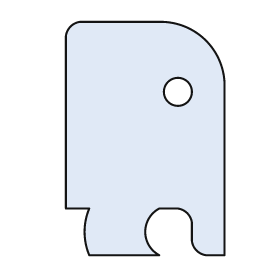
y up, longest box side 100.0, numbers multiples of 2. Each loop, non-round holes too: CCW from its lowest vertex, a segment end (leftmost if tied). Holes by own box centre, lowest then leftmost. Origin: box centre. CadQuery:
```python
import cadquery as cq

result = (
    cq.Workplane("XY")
    .moveTo(-24.0, -50.0)
    .lineTo(6.0, -50.0)
    .threePointArc((0.0, -40.0), (6.0, -30.0))
    .lineTo(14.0, -30.0)
    .threePointArc((18.0, -32.0), (20.0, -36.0))
    .lineTo(20.0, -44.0)
    .threePointArc((22.0, -48.0), (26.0, -50.0))
    .lineTo(34.0, -50.0)
    .lineTo(34.0, 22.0)
    .threePointArc((26.0, 42.0), (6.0, 50.0))
    .lineTo(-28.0, 50.0)
    .threePointArc((-32.0, 48.0), (-34.0, 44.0))
    .lineTo(-34.0, -30.0)
    .lineTo(-24.0, -30.0)
    .threePointArc((-26.0, -40.0), (-24.0, -50.0))
    .close()
    .moveTo(14.0, 20.0)
    .circle(6.0)
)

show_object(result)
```